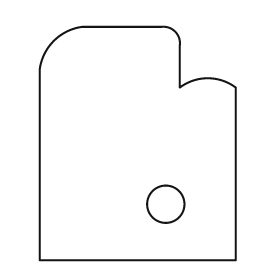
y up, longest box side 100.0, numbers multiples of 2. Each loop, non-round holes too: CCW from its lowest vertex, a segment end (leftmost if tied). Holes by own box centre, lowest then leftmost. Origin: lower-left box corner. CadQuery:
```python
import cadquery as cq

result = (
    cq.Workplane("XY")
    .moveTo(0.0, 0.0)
    .lineTo(84.0, 0.0)
    .lineTo(84.0, 74.0)
    .threePointArc((72.0, 78.0), (60.0, 74.0))
    .lineTo(60.0, 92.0)
    .threePointArc((58.0, 98.0), (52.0, 100.0))
    .lineTo(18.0, 100.0)
    .threePointArc((6.0, 94.0), (0.0, 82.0))
    .close()
    .moveTo(54.0, 24.0)
    .circle(8.0)
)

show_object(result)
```